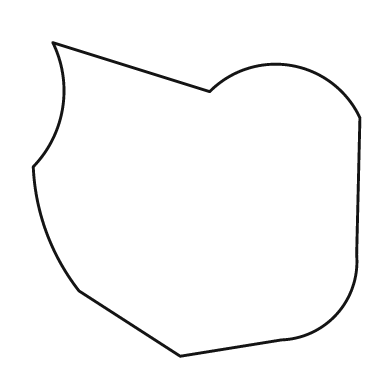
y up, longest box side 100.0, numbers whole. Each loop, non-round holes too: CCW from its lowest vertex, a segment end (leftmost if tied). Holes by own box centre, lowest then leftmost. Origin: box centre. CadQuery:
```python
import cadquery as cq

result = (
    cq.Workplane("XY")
    .moveTo(-5.0, -48.0)
    .lineTo(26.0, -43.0)
    .threePointArc((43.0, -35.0), (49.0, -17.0))
    .lineTo(50.0, 25.0)
    .threePointArc((29.0, 41.0), (4.0, 33.0))
    .lineTo(-44.0, 48.0)
    .threePointArc((-41.0, 28.0), (-50.0, 10.0))
    .threePointArc((-46.0, -10.0), (-36.0, -28.0))
    .close()
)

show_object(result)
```